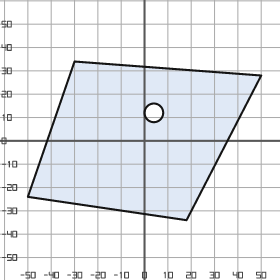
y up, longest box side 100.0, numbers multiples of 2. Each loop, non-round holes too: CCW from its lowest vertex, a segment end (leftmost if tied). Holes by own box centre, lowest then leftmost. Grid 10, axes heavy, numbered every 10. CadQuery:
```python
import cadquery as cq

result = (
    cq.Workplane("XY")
    .moveTo(18.0, -34.0)
    .lineTo(50.0, 28.0)
    .lineTo(-30.0, 34.0)
    .lineTo(-50.0, -24.0)
    .close()
    .moveTo(4.0, 12.0)
    .circle(4.0)
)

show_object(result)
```